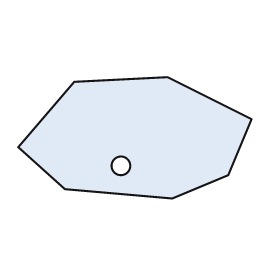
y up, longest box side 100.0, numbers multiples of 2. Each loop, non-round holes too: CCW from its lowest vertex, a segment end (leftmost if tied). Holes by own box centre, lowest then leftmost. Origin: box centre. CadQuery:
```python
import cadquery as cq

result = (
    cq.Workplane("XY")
    .moveTo(16.0, -26.0)
    .lineTo(40.0, -16.0)
    .lineTo(50.0, 8.0)
    .lineTo(14.0, 26.0)
    .lineTo(-26.0, 24.0)
    .lineTo(-50.0, -4.0)
    .lineTo(-30.0, -22.0)
    .close()
    .moveTo(-6.0, -12.0)
    .circle(4.0)
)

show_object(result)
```